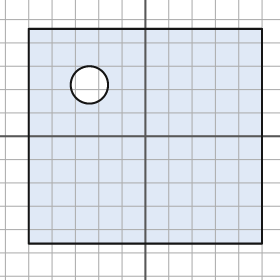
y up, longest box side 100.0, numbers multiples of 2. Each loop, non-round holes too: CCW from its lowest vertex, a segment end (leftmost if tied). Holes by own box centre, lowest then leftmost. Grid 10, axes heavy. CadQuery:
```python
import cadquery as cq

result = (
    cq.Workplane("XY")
    .moveTo(-50.0, -46.0)
    .lineTo(50.0, -46.0)
    .lineTo(50.0, 46.0)
    .lineTo(-50.0, 46.0)
    .close()
    .moveTo(-24.0, 22.0)
    .circle(8.0)
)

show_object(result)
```